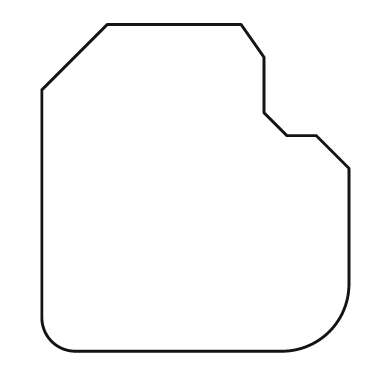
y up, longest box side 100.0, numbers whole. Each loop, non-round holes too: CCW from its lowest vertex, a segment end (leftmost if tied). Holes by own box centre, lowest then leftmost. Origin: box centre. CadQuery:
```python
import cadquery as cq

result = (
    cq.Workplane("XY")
    .moveTo(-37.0, -50.0)
    .lineTo(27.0, -50.0)
    .threePointArc((41.0, -44.0), (47.0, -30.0))
    .lineTo(47.0, 6.0)
    .lineTo(37.0, 16.0)
    .lineTo(28.0, 16.0)
    .lineTo(21.0, 23.0)
    .lineTo(21.0, 40.0)
    .lineTo(14.0, 50.0)
    .lineTo(-27.0, 50.0)
    .lineTo(-47.0, 30.0)
    .lineTo(-47.0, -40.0)
    .threePointArc((-44.0, -47.0), (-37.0, -50.0))
    .close()
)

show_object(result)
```